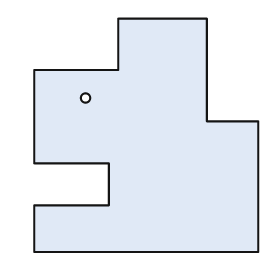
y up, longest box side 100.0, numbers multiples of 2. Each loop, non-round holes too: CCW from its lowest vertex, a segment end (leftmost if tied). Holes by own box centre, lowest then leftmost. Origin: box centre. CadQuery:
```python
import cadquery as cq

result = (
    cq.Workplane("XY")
    .moveTo(-48.0, -50.0)
    .lineTo(48.0, -50.0)
    .lineTo(48.0, 6.0)
    .lineTo(26.0, 6.0)
    .lineTo(26.0, 50.0)
    .lineTo(-12.0, 50.0)
    .lineTo(-12.0, 28.0)
    .lineTo(-48.0, 28.0)
    .lineTo(-48.0, -12.0)
    .lineTo(-16.0, -12.0)
    .lineTo(-16.0, -30.0)
    .lineTo(-48.0, -30.0)
    .close()
    .moveTo(-26.0, 16.0)
    .circle(2.0)
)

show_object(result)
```